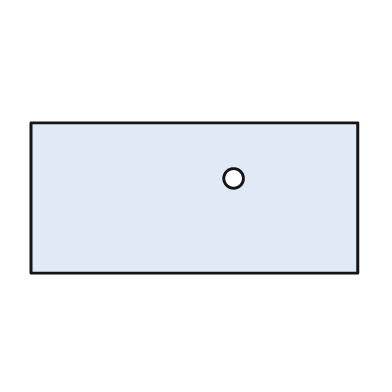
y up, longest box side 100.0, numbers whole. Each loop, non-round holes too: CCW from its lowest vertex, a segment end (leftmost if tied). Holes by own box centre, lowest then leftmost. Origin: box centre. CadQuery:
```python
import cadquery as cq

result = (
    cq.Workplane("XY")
    .moveTo(-50.0, -23.0)
    .lineTo(50.0, -23.0)
    .lineTo(50.0, 23.0)
    .lineTo(-50.0, 23.0)
    .close()
    .moveTo(12.0, 6.0)
    .circle(3.0)
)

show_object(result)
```